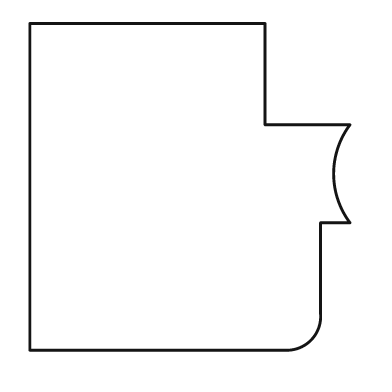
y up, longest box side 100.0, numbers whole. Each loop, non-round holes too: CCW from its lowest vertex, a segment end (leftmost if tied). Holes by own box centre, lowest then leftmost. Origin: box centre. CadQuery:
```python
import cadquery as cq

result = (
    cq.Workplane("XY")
    .moveTo(-49.0, -50.0)
    .lineTo(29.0, -50.0)
    .threePointArc((37.0, -47.0), (40.0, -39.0))
    .lineTo(40.0, -11.0)
    .lineTo(49.0, -11.0)
    .threePointArc((44.0, 4.0), (49.0, 19.0))
    .lineTo(23.0, 19.0)
    .lineTo(23.0, 50.0)
    .lineTo(-49.0, 50.0)
    .close()
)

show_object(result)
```